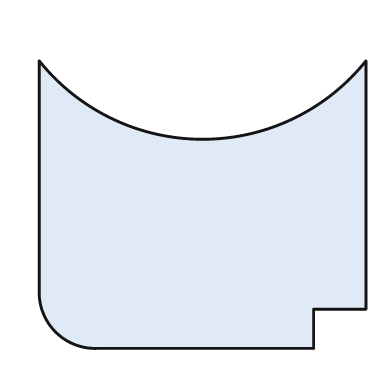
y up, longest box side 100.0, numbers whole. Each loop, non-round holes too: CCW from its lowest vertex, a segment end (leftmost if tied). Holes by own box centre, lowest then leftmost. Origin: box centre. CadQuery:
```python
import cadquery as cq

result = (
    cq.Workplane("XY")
    .moveTo(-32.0, -44.0)
    .lineTo(34.0, -44.0)
    .lineTo(34.0, -32.0)
    .lineTo(50.0, -32.0)
    .lineTo(50.0, 44.0)
    .threePointArc((0.0, 20.0), (-50.0, 44.0))
    .lineTo(-50.0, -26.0)
    .threePointArc((-45.0, -39.0), (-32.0, -44.0))
    .close()
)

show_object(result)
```